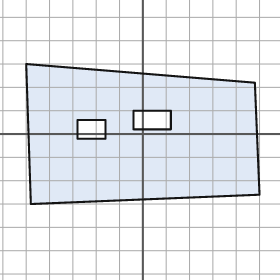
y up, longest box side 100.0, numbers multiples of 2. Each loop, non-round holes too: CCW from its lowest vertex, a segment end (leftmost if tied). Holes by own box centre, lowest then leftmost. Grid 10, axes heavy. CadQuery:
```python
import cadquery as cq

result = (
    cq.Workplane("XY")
    .moveTo(-48.0, -30.0)
    .lineTo(50.0, -26.0)
    .lineTo(48.0, 22.0)
    .lineTo(-50.0, 30.0)
    .close()
    .moveTo(-28.0, -2.0)
    .lineTo(-16.0, -2.0)
    .lineTo(-16.0, 6.0)
    .lineTo(-28.0, 6.0)
    .close()
    .moveTo(-4.0, 2.0)
    .lineTo(12.0, 2.0)
    .lineTo(12.0, 10.0)
    .lineTo(-4.0, 10.0)
    .close()
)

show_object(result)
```